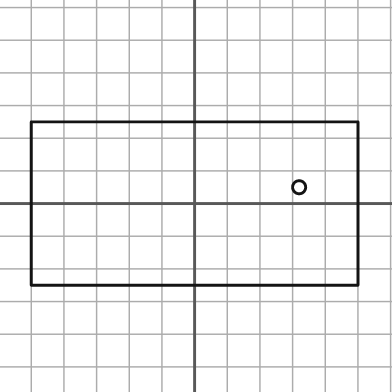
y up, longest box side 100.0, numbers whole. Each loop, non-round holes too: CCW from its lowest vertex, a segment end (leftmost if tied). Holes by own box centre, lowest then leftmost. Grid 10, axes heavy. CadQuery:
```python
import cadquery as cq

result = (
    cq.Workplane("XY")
    .moveTo(-50.0, -25.0)
    .lineTo(50.0, -25.0)
    .lineTo(50.0, 25.0)
    .lineTo(-50.0, 25.0)
    .close()
    .moveTo(32.0, 5.0)
    .circle(2.0)
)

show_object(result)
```